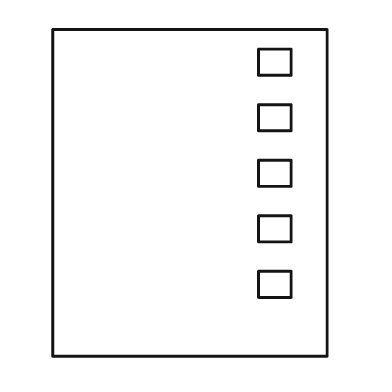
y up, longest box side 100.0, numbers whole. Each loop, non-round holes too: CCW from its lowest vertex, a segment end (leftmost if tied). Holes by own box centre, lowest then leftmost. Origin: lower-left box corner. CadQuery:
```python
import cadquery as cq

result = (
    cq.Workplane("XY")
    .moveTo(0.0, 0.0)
    .lineTo(84.0, 0.0)
    .lineTo(84.0, 100.0)
    .lineTo(0.0, 100.0)
    .close()
    .moveTo(63.0, 18.0)
    .lineTo(73.0, 18.0)
    .lineTo(73.0, 26.0)
    .lineTo(63.0, 26.0)
    .close()
    .moveTo(63.0, 35.0)
    .lineTo(73.0, 35.0)
    .lineTo(73.0, 43.0)
    .lineTo(63.0, 43.0)
    .close()
    .moveTo(63.0, 52.0)
    .lineTo(73.0, 52.0)
    .lineTo(73.0, 60.0)
    .lineTo(63.0, 60.0)
    .close()
    .moveTo(63.0, 69.0)
    .lineTo(73.0, 69.0)
    .lineTo(73.0, 77.0)
    .lineTo(63.0, 77.0)
    .close()
    .moveTo(63.0, 86.0)
    .lineTo(73.0, 86.0)
    .lineTo(73.0, 94.0)
    .lineTo(63.0, 94.0)
    .close()
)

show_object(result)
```